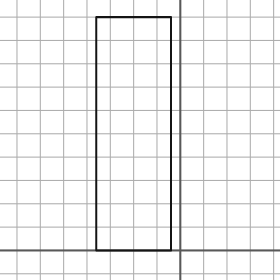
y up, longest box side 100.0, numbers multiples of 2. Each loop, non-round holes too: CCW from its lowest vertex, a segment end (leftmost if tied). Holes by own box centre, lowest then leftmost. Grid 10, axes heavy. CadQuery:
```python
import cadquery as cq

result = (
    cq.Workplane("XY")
    .moveTo(-36.0, 0.0)
    .lineTo(-4.0, 0.0)
    .lineTo(-4.0, 100.0)
    .lineTo(-36.0, 100.0)
    .close()
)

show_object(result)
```